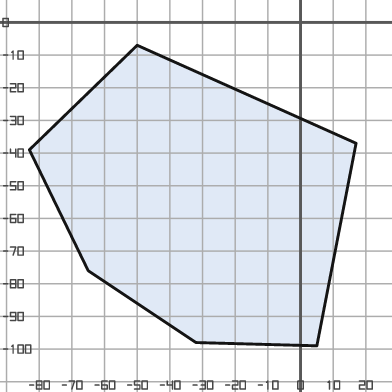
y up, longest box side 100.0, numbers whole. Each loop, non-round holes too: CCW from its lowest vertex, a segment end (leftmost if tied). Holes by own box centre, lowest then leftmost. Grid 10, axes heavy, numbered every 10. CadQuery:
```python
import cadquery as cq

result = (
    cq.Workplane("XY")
    .moveTo(5.0, -99.0)
    .lineTo(17.0, -37.0)
    .lineTo(-50.0, -7.0)
    .lineTo(-83.0, -39.0)
    .lineTo(-65.0, -76.0)
    .lineTo(-32.0, -98.0)
    .close()
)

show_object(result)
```